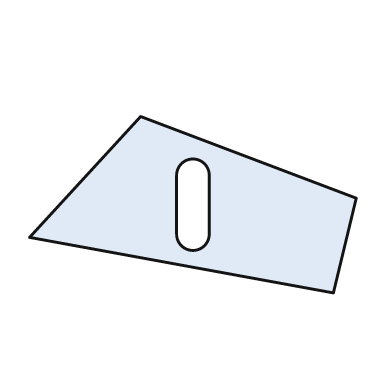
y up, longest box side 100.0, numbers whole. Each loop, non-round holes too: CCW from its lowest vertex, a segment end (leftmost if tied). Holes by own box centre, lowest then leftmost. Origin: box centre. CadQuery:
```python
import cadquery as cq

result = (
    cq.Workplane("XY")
    .moveTo(43.0, -27.0)
    .lineTo(50.0, 2.0)
    .lineTo(-16.0, 27.0)
    .lineTo(-50.0, -10.0)
    .close()
    .moveTo(-5.0, -9.0)
    .threePointArc((0.0, -14.0), (5.0, -9.0))
    .lineTo(5.0, 9.0)
    .threePointArc((0.0, 14.0), (-5.0, 9.0))
    .close()
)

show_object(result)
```